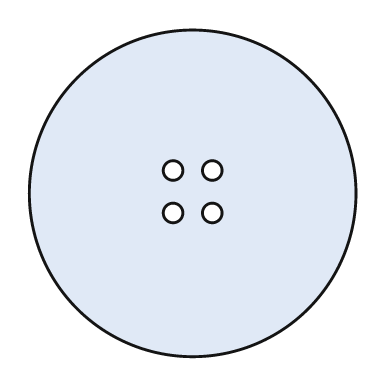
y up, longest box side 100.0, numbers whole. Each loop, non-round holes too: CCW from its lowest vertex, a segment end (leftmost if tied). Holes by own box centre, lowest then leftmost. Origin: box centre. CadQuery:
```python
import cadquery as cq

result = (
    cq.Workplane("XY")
    .moveTo(0.0, 0.0)
    .circle(50.0)
    .moveTo(-6.0, -6.0)
    .circle(3.0)
    .moveTo(6.0, -6.0)
    .circle(3.0)
    .moveTo(-6.0, 7.0)
    .circle(3.0)
    .moveTo(6.0, 7.0)
    .circle(3.0)
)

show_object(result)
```